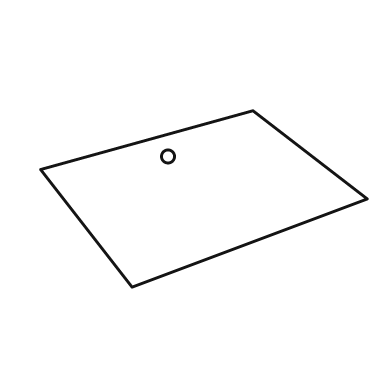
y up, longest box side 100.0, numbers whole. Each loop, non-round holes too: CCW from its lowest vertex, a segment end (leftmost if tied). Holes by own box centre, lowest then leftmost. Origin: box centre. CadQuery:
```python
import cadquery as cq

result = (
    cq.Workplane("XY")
    .moveTo(-22.0, -27.0)
    .lineTo(50.0, 0.0)
    .lineTo(15.0, 27.0)
    .lineTo(-50.0, 9.0)
    .close()
    .moveTo(-11.0, 13.0)
    .circle(2.0)
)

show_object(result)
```